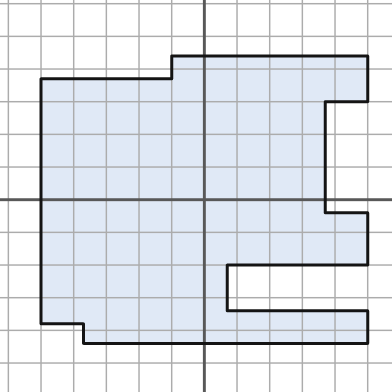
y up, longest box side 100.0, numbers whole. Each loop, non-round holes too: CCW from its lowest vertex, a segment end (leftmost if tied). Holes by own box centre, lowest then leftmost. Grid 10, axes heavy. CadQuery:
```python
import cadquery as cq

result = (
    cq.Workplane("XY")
    .moveTo(-37.0, -44.0)
    .lineTo(50.0, -44.0)
    .lineTo(50.0, -34.0)
    .lineTo(7.0, -34.0)
    .lineTo(7.0, -20.0)
    .lineTo(50.0, -20.0)
    .lineTo(50.0, -4.0)
    .lineTo(37.0, -4.0)
    .lineTo(37.0, 30.0)
    .lineTo(50.0, 30.0)
    .lineTo(50.0, 44.0)
    .lineTo(-10.0, 44.0)
    .lineTo(-10.0, 37.0)
    .lineTo(-50.0, 37.0)
    .lineTo(-50.0, -38.0)
    .lineTo(-37.0, -38.0)
    .close()
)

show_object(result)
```